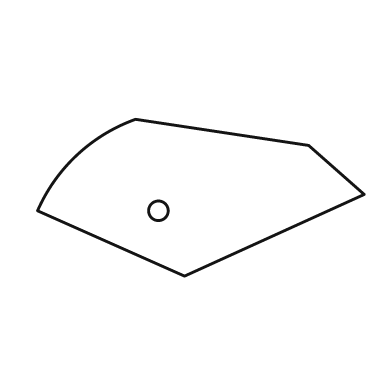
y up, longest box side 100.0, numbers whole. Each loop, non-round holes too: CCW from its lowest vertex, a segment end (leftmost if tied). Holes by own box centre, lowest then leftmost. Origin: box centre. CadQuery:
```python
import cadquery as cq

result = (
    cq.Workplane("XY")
    .moveTo(-5.0, -24.0)
    .lineTo(50.0, 1.0)
    .lineTo(33.0, 16.0)
    .lineTo(-20.0, 24.0)
    .threePointArc((-38.0, 13.0), (-50.0, -4.0))
    .close()
    .moveTo(-13.0, -4.0)
    .circle(3.0)
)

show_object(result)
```